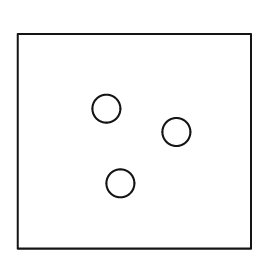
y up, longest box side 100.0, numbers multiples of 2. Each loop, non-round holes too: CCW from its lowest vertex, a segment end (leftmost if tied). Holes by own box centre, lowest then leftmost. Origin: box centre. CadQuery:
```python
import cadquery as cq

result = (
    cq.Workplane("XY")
    .moveTo(-50.0, -46.0)
    .lineTo(50.0, -46.0)
    .lineTo(50.0, 46.0)
    .lineTo(-50.0, 46.0)
    .close()
    .moveTo(-6.0, -18.0)
    .circle(6.0)
    .moveTo(18.0, 4.0)
    .circle(6.0)
    .moveTo(-12.0, 14.0)
    .circle(6.0)
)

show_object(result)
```